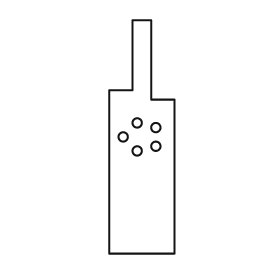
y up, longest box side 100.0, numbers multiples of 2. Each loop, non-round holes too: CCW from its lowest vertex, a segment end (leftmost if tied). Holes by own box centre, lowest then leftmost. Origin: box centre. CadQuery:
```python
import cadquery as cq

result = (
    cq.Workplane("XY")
    .moveTo(-14.0, -50.0)
    .lineTo(14.0, -50.0)
    .lineTo(14.0, 16.0)
    .lineTo(4.0, 16.0)
    .lineTo(4.0, 50.0)
    .lineTo(-4.0, 50.0)
    .lineTo(-4.0, 20.0)
    .lineTo(-14.0, 20.0)
    .close()
    .moveTo(-2.0, -6.0)
    .circle(2.0)
    .moveTo(6.0, -4.0)
    .circle(2.0)
    .moveTo(-8.0, 0.0)
    .circle(2.0)
    .moveTo(6.0, 4.0)
    .circle(2.0)
    .moveTo(-2.0, 6.0)
    .circle(2.0)
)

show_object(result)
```